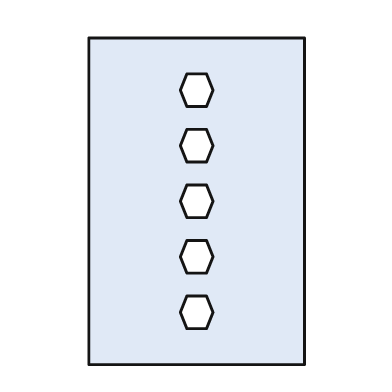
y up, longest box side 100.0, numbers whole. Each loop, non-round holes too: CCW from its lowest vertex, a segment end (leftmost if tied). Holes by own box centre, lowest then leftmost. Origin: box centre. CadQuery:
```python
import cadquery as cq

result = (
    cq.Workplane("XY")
    .moveTo(-33.0, -50.0)
    .lineTo(33.0, -50.0)
    .lineTo(33.0, 50.0)
    .lineTo(-33.0, 50.0)
    .close()
    .moveTo(-3.0, -39.0)
    .lineTo(3.0, -39.0)
    .lineTo(5.0, -34.0)
    .lineTo(3.0, -29.0)
    .lineTo(-3.0, -29.0)
    .lineTo(-5.0, -34.0)
    .close()
    .moveTo(-3.0, -22.0)
    .lineTo(3.0, -22.0)
    .lineTo(5.0, -17.0)
    .lineTo(3.0, -12.0)
    .lineTo(-3.0, -12.0)
    .lineTo(-5.0, -17.0)
    .close()
    .moveTo(-3.0, -5.0)
    .lineTo(3.0, -5.0)
    .lineTo(5.0, 0.0)
    .lineTo(3.0, 5.0)
    .lineTo(-3.0, 5.0)
    .lineTo(-5.0, 0.0)
    .close()
    .moveTo(-3.0, 12.0)
    .lineTo(3.0, 12.0)
    .lineTo(5.0, 17.0)
    .lineTo(3.0, 22.0)
    .lineTo(-3.0, 22.0)
    .lineTo(-5.0, 17.0)
    .close()
    .moveTo(-3.0, 29.0)
    .lineTo(3.0, 29.0)
    .lineTo(5.0, 34.0)
    .lineTo(3.0, 39.0)
    .lineTo(-3.0, 39.0)
    .lineTo(-5.0, 34.0)
    .close()
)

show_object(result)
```